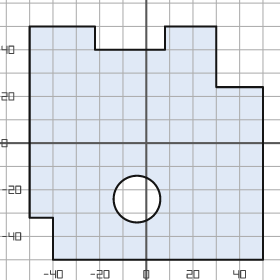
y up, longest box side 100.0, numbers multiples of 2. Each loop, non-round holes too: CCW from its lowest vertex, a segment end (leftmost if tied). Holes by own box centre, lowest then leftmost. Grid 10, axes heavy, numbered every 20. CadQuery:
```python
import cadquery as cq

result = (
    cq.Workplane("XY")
    .moveTo(-40.0, -50.0)
    .lineTo(50.0, -50.0)
    .lineTo(50.0, 24.0)
    .lineTo(30.0, 24.0)
    .lineTo(30.0, 50.0)
    .lineTo(8.0, 50.0)
    .lineTo(8.0, 40.0)
    .lineTo(-22.0, 40.0)
    .lineTo(-22.0, 50.0)
    .lineTo(-50.0, 50.0)
    .lineTo(-50.0, -32.0)
    .lineTo(-40.0, -32.0)
    .close()
    .moveTo(-4.0, -24.0)
    .circle(10.0)
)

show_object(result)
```